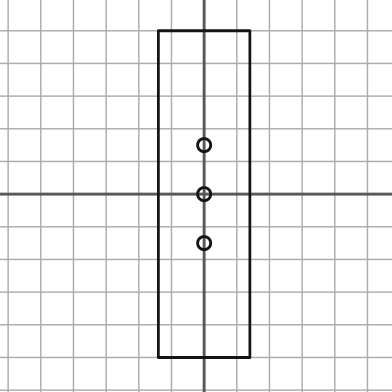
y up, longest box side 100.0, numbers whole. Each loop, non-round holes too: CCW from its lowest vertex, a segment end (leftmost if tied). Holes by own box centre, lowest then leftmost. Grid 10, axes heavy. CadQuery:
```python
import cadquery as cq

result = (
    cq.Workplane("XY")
    .moveTo(-14.0, -50.0)
    .lineTo(14.0, -50.0)
    .lineTo(14.0, 50.0)
    .lineTo(-14.0, 50.0)
    .close()
    .moveTo(0.0, -15.0)
    .circle(2.0)
    .moveTo(0.0, 0.0)
    .circle(2.0)
    .moveTo(0.0, 15.0)
    .circle(2.0)
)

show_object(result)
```